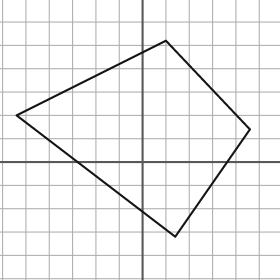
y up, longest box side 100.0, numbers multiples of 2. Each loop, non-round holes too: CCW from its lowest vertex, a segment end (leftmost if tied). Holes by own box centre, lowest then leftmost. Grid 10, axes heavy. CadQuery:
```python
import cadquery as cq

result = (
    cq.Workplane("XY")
    .moveTo(14.0, -32.0)
    .lineTo(46.0, 14.0)
    .lineTo(10.0, 52.0)
    .lineTo(-54.0, 20.0)
    .close()
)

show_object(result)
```